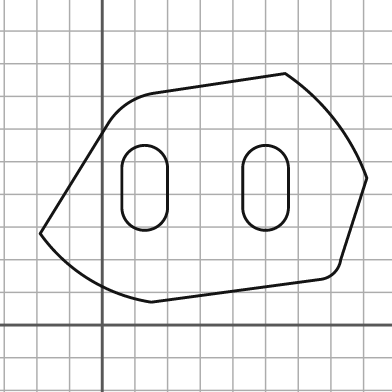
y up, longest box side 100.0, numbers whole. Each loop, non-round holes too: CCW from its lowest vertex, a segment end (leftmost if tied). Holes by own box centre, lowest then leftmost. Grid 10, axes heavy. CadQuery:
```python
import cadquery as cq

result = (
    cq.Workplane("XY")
    .moveTo(15.0, 7.0)
    .lineTo(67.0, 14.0)
    .threePointArc((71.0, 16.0), (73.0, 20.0))
    .lineTo(81.0, 45.0)
    .threePointArc((71.0, 63.0), (56.0, 77.0))
    .lineTo(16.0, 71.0)
    .threePointArc((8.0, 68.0), (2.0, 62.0))
    .lineTo(-19.0, 28.0)
    .threePointArc((-4.0, 14.0), (15.0, 7.0))
    .close()
    .moveTo(6.0, 36.0)
    .threePointArc((13.0, 29.0), (20.0, 36.0))
    .lineTo(20.0, 48.0)
    .threePointArc((13.0, 55.0), (6.0, 48.0))
    .close()
    .moveTo(43.0, 36.0)
    .threePointArc((50.0, 29.0), (57.0, 36.0))
    .lineTo(57.0, 48.0)
    .threePointArc((50.0, 55.0), (43.0, 48.0))
    .close()
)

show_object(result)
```